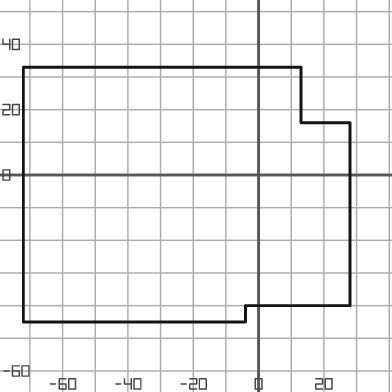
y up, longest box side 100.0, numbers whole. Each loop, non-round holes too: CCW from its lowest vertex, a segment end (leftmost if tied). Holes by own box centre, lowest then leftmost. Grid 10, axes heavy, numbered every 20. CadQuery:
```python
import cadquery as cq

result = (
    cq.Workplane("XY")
    .moveTo(-72.0, -45.0)
    .lineTo(-4.0, -45.0)
    .lineTo(-4.0, -40.0)
    .lineTo(28.0, -40.0)
    .lineTo(28.0, 16.0)
    .lineTo(13.0, 16.0)
    .lineTo(13.0, 33.0)
    .lineTo(-72.0, 33.0)
    .close()
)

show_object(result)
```